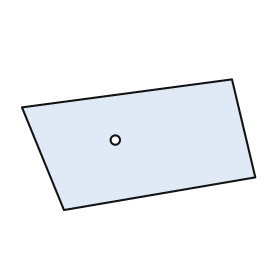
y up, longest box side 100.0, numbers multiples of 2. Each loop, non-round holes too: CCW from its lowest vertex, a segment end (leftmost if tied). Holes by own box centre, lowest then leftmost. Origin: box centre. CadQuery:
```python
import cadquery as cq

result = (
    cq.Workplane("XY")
    .moveTo(-32.0, -28.0)
    .lineTo(50.0, -14.0)
    .lineTo(40.0, 28.0)
    .lineTo(-50.0, 16.0)
    .close()
    .moveTo(-10.0, 2.0)
    .circle(2.0)
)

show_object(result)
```